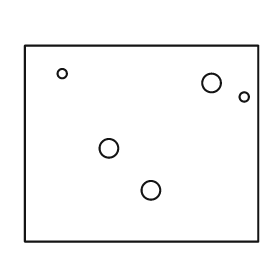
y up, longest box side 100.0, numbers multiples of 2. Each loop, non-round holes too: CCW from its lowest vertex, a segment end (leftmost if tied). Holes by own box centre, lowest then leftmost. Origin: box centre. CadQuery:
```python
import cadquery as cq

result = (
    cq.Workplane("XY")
    .moveTo(-50.0, -42.0)
    .lineTo(50.0, -42.0)
    .lineTo(50.0, 42.0)
    .lineTo(-50.0, 42.0)
    .close()
    .moveTo(4.0, -20.0)
    .circle(4.0)
    .moveTo(-14.0, -2.0)
    .circle(4.0)
    .moveTo(44.0, 20.0)
    .circle(2.0)
    .moveTo(30.0, 26.0)
    .circle(4.0)
    .moveTo(-34.0, 30.0)
    .circle(2.0)
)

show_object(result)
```